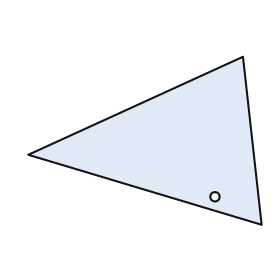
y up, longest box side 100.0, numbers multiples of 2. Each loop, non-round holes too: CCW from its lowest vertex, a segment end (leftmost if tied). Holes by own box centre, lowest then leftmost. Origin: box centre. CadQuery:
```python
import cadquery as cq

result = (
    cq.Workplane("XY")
    .moveTo(50.0, -36.0)
    .lineTo(42.0, 36.0)
    .lineTo(-50.0, -6.0)
    .close()
    .moveTo(30.0, -24.0)
    .circle(2.0)
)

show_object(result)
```